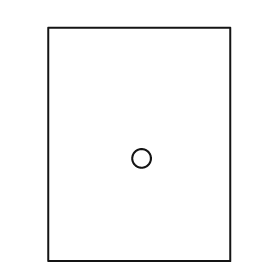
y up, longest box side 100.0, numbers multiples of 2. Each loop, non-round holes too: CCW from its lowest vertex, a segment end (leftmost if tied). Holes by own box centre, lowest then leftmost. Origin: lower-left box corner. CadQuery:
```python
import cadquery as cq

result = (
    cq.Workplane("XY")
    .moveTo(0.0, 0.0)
    .lineTo(78.0, 0.0)
    .lineTo(78.0, 100.0)
    .lineTo(0.0, 100.0)
    .close()
    .moveTo(40.0, 44.0)
    .circle(4.0)
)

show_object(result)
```